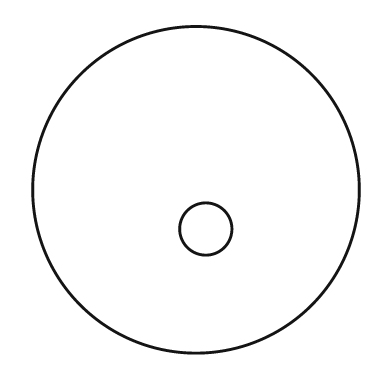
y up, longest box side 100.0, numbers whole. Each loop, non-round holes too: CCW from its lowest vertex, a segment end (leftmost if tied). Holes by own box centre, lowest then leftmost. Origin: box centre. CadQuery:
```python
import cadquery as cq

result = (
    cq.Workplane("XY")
    .moveTo(0.0, 0.0)
    .circle(50.0)
    .moveTo(3.0, -12.0)
    .circle(8.0)
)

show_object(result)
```